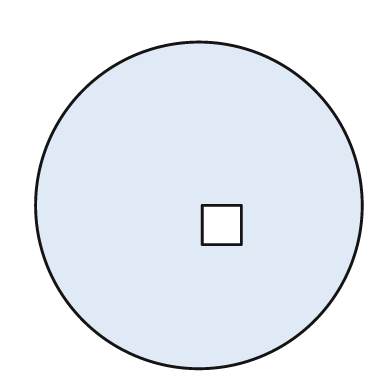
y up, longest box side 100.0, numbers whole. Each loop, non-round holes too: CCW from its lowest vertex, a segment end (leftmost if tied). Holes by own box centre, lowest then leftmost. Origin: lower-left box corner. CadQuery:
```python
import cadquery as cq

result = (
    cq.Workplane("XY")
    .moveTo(50.0, 50.0)
    .circle(50.0)
    .moveTo(51.0, 38.0)
    .lineTo(63.0, 38.0)
    .lineTo(63.0, 50.0)
    .lineTo(51.0, 50.0)
    .close()
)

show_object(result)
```